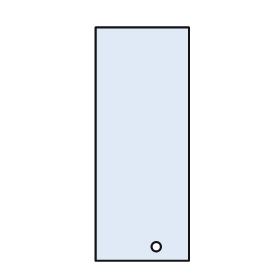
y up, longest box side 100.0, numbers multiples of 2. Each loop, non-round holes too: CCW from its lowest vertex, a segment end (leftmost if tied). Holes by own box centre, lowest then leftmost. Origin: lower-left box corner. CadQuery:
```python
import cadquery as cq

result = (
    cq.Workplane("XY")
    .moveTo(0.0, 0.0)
    .lineTo(40.0, 0.0)
    .lineTo(40.0, 100.0)
    .lineTo(0.0, 100.0)
    .close()
    .moveTo(26.0, 6.0)
    .circle(2.0)
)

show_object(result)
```